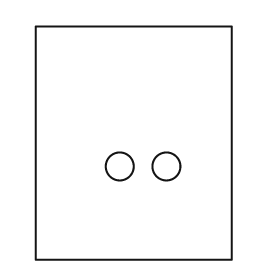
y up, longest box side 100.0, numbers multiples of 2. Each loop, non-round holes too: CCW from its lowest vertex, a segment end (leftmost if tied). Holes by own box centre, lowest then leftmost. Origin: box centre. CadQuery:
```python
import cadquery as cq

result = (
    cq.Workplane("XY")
    .moveTo(-42.0, -50.0)
    .lineTo(42.0, -50.0)
    .lineTo(42.0, 50.0)
    .lineTo(-42.0, 50.0)
    .close()
    .moveTo(-6.0, -10.0)
    .circle(6.0)
    .moveTo(14.0, -10.0)
    .circle(6.0)
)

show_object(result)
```